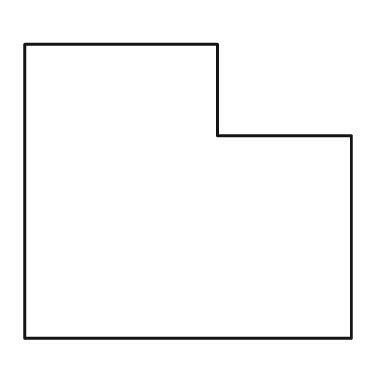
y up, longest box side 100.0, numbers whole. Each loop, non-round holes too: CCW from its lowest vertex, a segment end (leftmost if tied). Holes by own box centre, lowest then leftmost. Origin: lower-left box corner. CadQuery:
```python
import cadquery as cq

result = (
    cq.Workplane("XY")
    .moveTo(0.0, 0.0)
    .lineTo(100.0, 0.0)
    .lineTo(100.0, 62.0)
    .lineTo(59.0, 62.0)
    .lineTo(59.0, 90.0)
    .lineTo(0.0, 90.0)
    .close()
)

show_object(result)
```